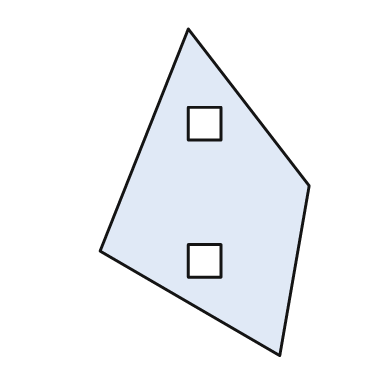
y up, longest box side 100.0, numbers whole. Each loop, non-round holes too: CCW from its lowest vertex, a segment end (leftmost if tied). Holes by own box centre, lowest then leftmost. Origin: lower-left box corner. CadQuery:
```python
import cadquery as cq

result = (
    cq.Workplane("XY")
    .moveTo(55.0, 0.0)
    .lineTo(64.0, 52.0)
    .lineTo(27.0, 100.0)
    .lineTo(0.0, 32.0)
    .close()
    .moveTo(27.0, 24.0)
    .lineTo(37.0, 24.0)
    .lineTo(37.0, 34.0)
    .lineTo(27.0, 34.0)
    .close()
    .moveTo(27.0, 66.0)
    .lineTo(37.0, 66.0)
    .lineTo(37.0, 76.0)
    .lineTo(27.0, 76.0)
    .close()
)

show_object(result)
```